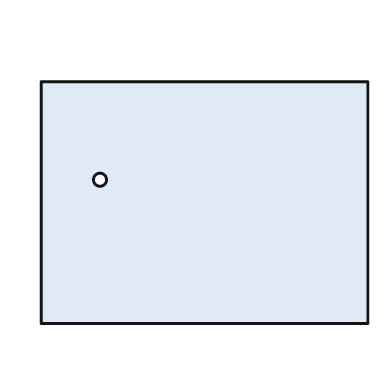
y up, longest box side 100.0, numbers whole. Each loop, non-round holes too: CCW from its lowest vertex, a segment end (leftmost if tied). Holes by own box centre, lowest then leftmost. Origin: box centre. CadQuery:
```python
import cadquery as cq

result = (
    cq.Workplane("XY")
    .moveTo(-50.0, -37.0)
    .lineTo(50.0, -37.0)
    .lineTo(50.0, 37.0)
    .lineTo(-50.0, 37.0)
    .close()
    .moveTo(-32.0, 7.0)
    .circle(2.0)
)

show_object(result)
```